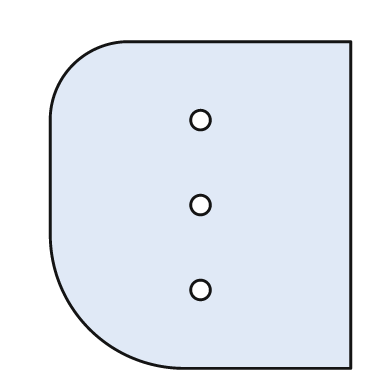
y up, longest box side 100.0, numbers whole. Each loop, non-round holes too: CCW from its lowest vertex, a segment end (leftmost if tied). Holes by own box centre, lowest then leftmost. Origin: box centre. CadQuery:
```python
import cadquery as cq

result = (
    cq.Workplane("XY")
    .moveTo(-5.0, -50.0)
    .lineTo(46.0, -50.0)
    .lineTo(46.0, 50.0)
    .lineTo(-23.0, 50.0)
    .threePointArc((-39.0, 43.0), (-46.0, 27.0))
    .lineTo(-46.0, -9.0)
    .threePointArc((-34.0, -38.0), (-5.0, -50.0))
    .close()
    .moveTo(0.0, -26.0)
    .circle(3.0)
    .moveTo(0.0, 0.0)
    .circle(3.0)
    .moveTo(0.0, 26.0)
    .circle(3.0)
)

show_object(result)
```